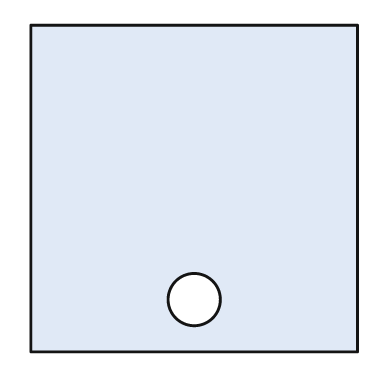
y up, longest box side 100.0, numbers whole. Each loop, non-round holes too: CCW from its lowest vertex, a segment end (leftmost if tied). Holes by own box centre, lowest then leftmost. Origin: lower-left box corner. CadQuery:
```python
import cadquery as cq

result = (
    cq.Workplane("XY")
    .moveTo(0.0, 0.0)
    .lineTo(100.0, 0.0)
    .lineTo(100.0, 100.0)
    .lineTo(0.0, 100.0)
    .close()
    .moveTo(50.0, 16.0)
    .circle(8.0)
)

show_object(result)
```